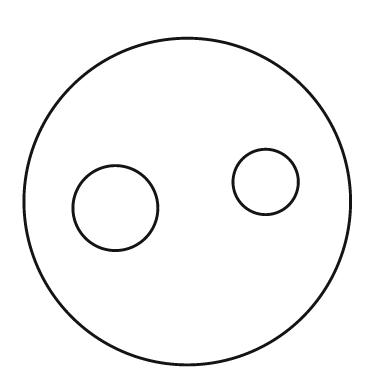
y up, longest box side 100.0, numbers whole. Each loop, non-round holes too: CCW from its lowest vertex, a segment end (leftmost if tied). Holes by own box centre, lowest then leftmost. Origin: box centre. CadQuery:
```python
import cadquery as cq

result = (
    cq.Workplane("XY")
    .moveTo(0.0, 0.0)
    .circle(50.0)
    .moveTo(-22.0, -2.0)
    .circle(13.0)
    .moveTo(24.0, 6.0)
    .circle(10.0)
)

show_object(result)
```